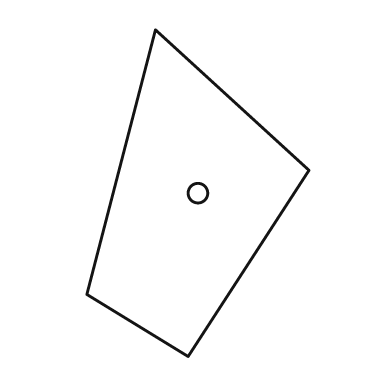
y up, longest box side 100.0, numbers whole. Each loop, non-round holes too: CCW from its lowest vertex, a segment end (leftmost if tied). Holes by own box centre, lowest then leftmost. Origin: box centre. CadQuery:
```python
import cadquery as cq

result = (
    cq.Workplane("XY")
    .moveTo(-3.0, -50.0)
    .lineTo(34.0, 7.0)
    .lineTo(-13.0, 50.0)
    .lineTo(-34.0, -31.0)
    .close()
    .moveTo(0.0, 0.0)
    .circle(3.0)
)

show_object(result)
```